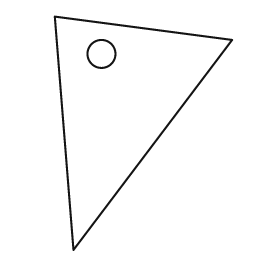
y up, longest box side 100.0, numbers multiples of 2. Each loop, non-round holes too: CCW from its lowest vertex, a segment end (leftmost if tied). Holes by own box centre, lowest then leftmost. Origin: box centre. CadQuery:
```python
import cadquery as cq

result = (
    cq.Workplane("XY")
    .moveTo(-30.0, -50.0)
    .lineTo(38.0, 40.0)
    .lineTo(-38.0, 50.0)
    .close()
    .moveTo(-18.0, 34.0)
    .circle(6.0)
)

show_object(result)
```